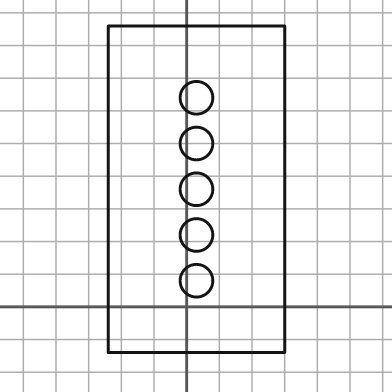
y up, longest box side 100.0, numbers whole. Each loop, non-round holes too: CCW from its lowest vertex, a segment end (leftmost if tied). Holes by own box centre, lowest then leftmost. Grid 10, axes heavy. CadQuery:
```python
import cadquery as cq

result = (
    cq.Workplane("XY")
    .moveTo(-24.0, -14.0)
    .lineTo(30.0, -14.0)
    .lineTo(30.0, 86.0)
    .lineTo(-24.0, 86.0)
    .close()
    .moveTo(3.0, 8.0)
    .circle(5.0)
    .moveTo(3.0, 22.0)
    .circle(5.0)
    .moveTo(3.0, 36.0)
    .circle(5.0)
    .moveTo(3.0, 50.0)
    .circle(5.0)
    .moveTo(3.0, 64.0)
    .circle(5.0)
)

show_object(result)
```